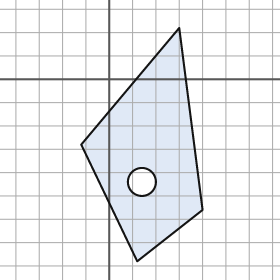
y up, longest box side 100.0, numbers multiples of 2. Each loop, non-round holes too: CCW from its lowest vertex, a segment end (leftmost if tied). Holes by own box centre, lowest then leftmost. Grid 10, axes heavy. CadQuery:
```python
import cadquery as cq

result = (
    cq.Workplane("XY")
    .moveTo(12.0, -78.0)
    .lineTo(40.0, -56.0)
    .lineTo(30.0, 22.0)
    .lineTo(-12.0, -28.0)
    .close()
    .moveTo(14.0, -44.0)
    .circle(6.0)
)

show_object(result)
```